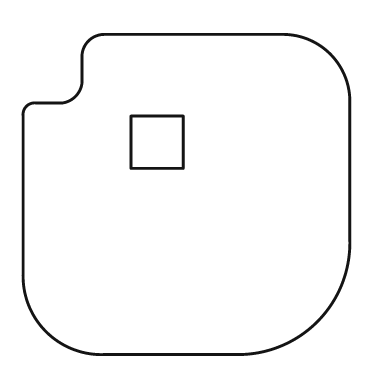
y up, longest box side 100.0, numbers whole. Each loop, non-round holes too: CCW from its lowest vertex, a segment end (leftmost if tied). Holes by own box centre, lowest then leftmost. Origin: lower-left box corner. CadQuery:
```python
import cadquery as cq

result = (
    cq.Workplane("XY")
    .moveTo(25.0, 0.0)
    .lineTo(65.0, 0.0)
    .threePointArc((90.0, 10.0), (100.0, 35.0))
    .lineTo(100.0, 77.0)
    .threePointArc((94.0, 92.0), (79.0, 98.0))
    .lineTo(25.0, 98.0)
    .threePointArc((20.0, 96.0), (18.0, 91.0))
    .lineTo(18.0, 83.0)
    .threePointArc((16.0, 79.0), (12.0, 77.0))
    .lineTo(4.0, 77.0)
    .threePointArc((1.0, 76.0), (0.0, 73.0))
    .lineTo(0.0, 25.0)
    .threePointArc((7.0, 7.0), (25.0, 0.0))
    .close()
    .moveTo(33.0, 57.0)
    .lineTo(49.0, 57.0)
    .lineTo(49.0, 73.0)
    .lineTo(33.0, 73.0)
    .close()
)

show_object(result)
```